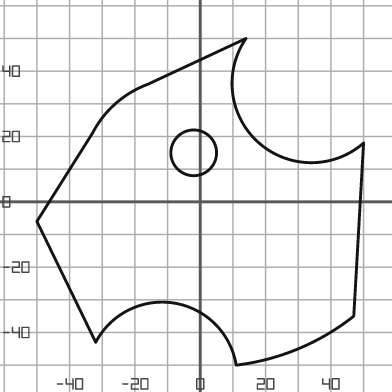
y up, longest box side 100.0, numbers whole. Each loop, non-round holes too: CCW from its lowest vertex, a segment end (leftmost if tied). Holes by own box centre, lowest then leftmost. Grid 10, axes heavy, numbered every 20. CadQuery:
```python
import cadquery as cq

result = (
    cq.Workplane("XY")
    .moveTo(11.0, -50.0)
    .threePointArc((30.0, -45.0), (47.0, -35.0))
    .lineTo(50.0, 18.0)
    .threePointArc((18.0, 18.0), (14.0, 50.0))
    .lineTo(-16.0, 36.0)
    .threePointArc((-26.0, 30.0), (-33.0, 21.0))
    .lineTo(-50.0, -6.0)
    .lineTo(-32.0, -43.0)
    .threePointArc((-8.0, -31.0), (11.0, -50.0))
    .close()
    .moveTo(-2.0, 15.0)
    .circle(7.0)
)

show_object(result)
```